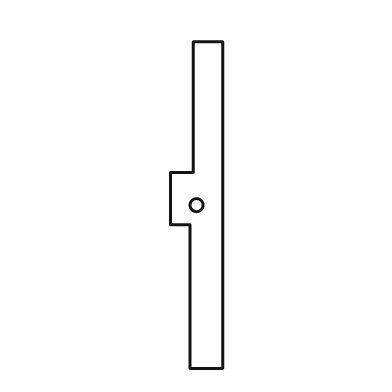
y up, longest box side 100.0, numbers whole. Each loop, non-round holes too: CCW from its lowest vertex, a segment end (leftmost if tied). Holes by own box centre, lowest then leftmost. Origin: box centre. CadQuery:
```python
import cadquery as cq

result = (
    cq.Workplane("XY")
    .moveTo(-2.0, -50.0)
    .lineTo(8.0, -50.0)
    .lineTo(8.0, 50.0)
    .lineTo(-1.0, 50.0)
    .lineTo(-1.0, 10.0)
    .lineTo(-8.0, 10.0)
    .lineTo(-8.0, -6.0)
    .lineTo(-2.0, -6.0)
    .close()
    .moveTo(0.0, 0.0)
    .circle(2.0)
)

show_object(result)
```